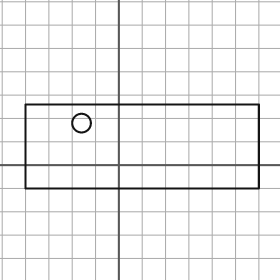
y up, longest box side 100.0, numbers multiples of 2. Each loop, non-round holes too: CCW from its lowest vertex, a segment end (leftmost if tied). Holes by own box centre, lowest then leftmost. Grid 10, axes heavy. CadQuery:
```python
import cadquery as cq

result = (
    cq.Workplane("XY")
    .moveTo(-40.0, -10.0)
    .lineTo(60.0, -10.0)
    .lineTo(60.0, 26.0)
    .lineTo(-40.0, 26.0)
    .close()
    .moveTo(-16.0, 18.0)
    .circle(4.0)
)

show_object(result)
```